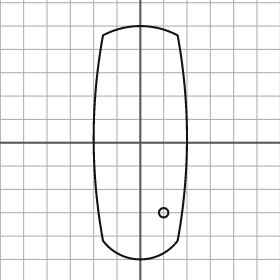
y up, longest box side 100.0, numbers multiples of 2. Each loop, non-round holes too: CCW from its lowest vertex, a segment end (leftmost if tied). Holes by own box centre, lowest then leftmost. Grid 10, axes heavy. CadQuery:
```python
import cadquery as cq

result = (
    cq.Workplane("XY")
    .moveTo(-16.0, -42.0)
    .threePointArc((0.0, -50.0), (16.0, -42.0))
    .threePointArc((20.0, 2.0), (16.0, 46.0))
    .threePointArc((0.0, 50.0), (-16.0, 46.0))
    .threePointArc((-20.0, 2.0), (-16.0, -42.0))
    .close()
    .moveTo(10.0, -30.0)
    .circle(2.0)
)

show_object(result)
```